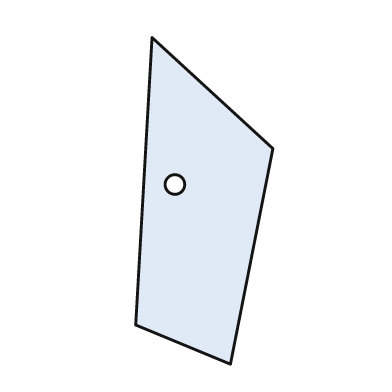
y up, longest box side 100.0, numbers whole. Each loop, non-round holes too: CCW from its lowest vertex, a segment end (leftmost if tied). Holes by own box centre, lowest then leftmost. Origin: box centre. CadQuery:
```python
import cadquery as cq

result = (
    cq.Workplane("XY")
    .moveTo(8.0, -50.0)
    .lineTo(21.0, 16.0)
    .lineTo(-16.0, 50.0)
    .lineTo(-21.0, -38.0)
    .close()
    .moveTo(-9.0, 5.0)
    .circle(3.0)
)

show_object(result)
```